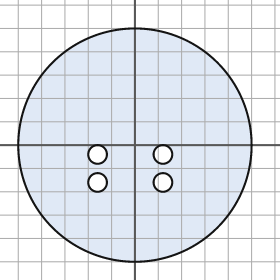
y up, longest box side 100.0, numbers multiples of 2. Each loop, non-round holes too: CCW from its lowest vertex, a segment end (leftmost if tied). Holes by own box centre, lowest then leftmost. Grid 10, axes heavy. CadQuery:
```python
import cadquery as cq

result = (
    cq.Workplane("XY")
    .moveTo(0.0, 0.0)
    .circle(50.0)
    .moveTo(-16.0, -16.0)
    .circle(4.0)
    .moveTo(12.0, -16.0)
    .circle(4.0)
    .moveTo(-16.0, -4.0)
    .circle(4.0)
    .moveTo(12.0, -4.0)
    .circle(4.0)
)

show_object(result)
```